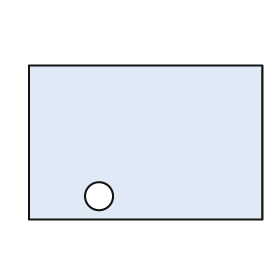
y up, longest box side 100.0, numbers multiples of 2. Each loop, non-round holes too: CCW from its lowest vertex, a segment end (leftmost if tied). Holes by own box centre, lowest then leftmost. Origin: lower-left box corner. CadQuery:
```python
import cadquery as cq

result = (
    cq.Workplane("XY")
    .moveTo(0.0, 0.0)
    .lineTo(100.0, 0.0)
    .lineTo(100.0, 66.0)
    .lineTo(0.0, 66.0)
    .close()
    .moveTo(30.0, 10.0)
    .circle(6.0)
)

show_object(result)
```